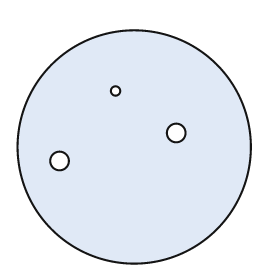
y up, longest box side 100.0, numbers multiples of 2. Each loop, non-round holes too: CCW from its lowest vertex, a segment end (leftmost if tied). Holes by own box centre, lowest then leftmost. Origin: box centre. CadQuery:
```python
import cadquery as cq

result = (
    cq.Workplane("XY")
    .moveTo(0.0, 0.0)
    .circle(50.0)
    .moveTo(-32.0, -6.0)
    .circle(4.0)
    .moveTo(18.0, 6.0)
    .circle(4.0)
    .moveTo(-8.0, 24.0)
    .circle(2.0)
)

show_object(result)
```